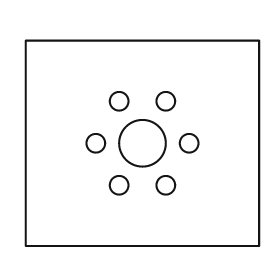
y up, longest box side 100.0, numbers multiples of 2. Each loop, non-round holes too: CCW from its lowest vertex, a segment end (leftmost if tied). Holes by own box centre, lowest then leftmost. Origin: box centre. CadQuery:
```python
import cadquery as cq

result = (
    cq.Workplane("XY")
    .moveTo(-50.0, -44.0)
    .lineTo(50.0, -44.0)
    .lineTo(50.0, 44.0)
    .lineTo(-50.0, 44.0)
    .close()
    .moveTo(-10.0, -18.0)
    .circle(4.0)
    .moveTo(10.0, -18.0)
    .circle(4.0)
    .moveTo(-20.0, 0.0)
    .circle(4.0)
    .moveTo(0.0, 0.0)
    .circle(10.0)
    .moveTo(20.0, 0.0)
    .circle(4.0)
    .moveTo(-10.0, 18.0)
    .circle(4.0)
    .moveTo(10.0, 18.0)
    .circle(4.0)
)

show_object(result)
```